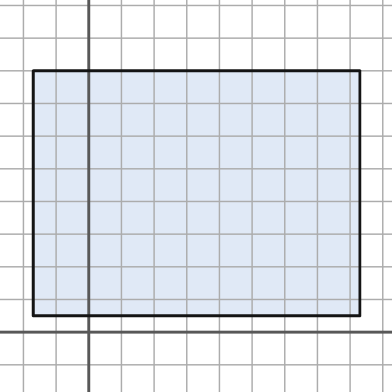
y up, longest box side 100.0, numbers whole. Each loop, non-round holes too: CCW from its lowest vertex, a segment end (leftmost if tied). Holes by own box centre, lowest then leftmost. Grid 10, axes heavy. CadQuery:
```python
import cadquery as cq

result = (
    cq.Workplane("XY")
    .moveTo(-17.0, 5.0)
    .lineTo(83.0, 5.0)
    .lineTo(83.0, 80.0)
    .lineTo(-17.0, 80.0)
    .close()
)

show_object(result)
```